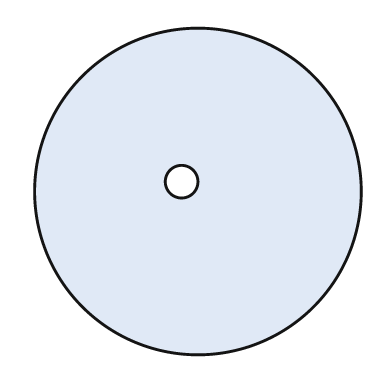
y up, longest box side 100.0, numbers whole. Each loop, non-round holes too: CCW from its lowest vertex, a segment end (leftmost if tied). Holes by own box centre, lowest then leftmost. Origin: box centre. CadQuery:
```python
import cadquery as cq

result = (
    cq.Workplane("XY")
    .moveTo(0.0, 0.0)
    .circle(50.0)
    .moveTo(-5.0, 3.0)
    .circle(5.0)
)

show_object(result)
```